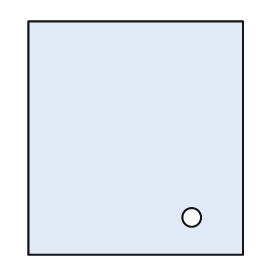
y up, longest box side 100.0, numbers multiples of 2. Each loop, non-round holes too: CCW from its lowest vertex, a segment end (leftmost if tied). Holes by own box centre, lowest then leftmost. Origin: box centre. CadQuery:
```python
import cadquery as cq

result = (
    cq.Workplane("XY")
    .moveTo(-46.0, -50.0)
    .lineTo(46.0, -50.0)
    .lineTo(46.0, 50.0)
    .lineTo(-46.0, 50.0)
    .close()
    .moveTo(24.0, -34.0)
    .circle(4.0)
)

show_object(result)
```